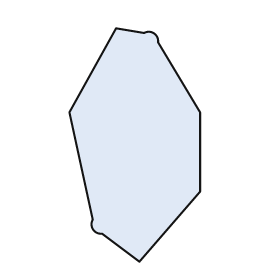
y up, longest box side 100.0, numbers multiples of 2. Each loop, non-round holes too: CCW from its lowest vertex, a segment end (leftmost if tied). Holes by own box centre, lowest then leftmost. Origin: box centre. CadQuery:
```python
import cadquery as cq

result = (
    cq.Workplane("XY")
    .moveTo(2.0, -50.0)
    .lineTo(28.0, -20.0)
    .lineTo(28.0, 14.0)
    .lineTo(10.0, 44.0)
    .threePointArc((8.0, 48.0), (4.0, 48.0))
    .lineTo(-8.0, 50.0)
    .lineTo(-28.0, 14.0)
    .lineTo(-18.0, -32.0)
    .threePointArc((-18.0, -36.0), (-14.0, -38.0))
    .close()
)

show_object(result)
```